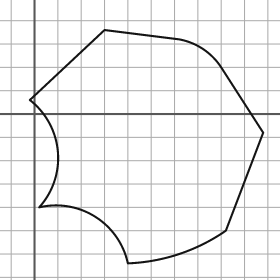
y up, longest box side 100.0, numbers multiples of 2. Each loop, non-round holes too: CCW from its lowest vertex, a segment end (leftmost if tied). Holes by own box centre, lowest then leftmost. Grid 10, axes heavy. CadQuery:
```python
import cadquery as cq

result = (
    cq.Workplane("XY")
    .moveTo(40.0, -64.0)
    .threePointArc((62.0, -60.0), (82.0, -50.0))
    .lineTo(98.0, -8.0)
    .lineTo(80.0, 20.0)
    .threePointArc((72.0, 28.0), (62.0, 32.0))
    .lineTo(30.0, 36.0)
    .lineTo(-2.0, 6.0)
    .threePointArc((10.0, -16.0), (2.0, -40.0))
    .threePointArc((26.0, -44.0), (40.0, -64.0))
    .close()
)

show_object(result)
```